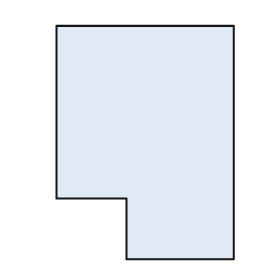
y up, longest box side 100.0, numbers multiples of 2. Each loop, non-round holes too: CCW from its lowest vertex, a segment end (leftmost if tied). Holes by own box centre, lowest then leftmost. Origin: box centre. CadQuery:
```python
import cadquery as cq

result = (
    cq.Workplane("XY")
    .moveTo(-8.0, -50.0)
    .lineTo(38.0, -50.0)
    .lineTo(38.0, 50.0)
    .lineTo(-38.0, 50.0)
    .lineTo(-38.0, -24.0)
    .lineTo(-8.0, -24.0)
    .close()
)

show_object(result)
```